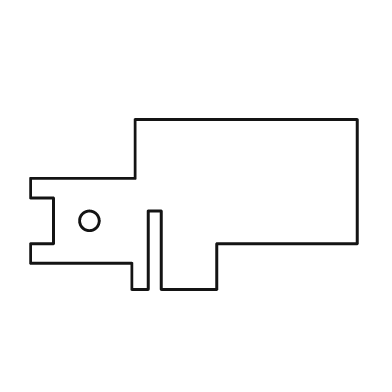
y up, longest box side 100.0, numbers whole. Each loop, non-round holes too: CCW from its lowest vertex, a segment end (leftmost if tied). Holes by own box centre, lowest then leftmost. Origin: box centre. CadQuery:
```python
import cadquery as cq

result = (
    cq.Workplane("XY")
    .moveTo(-19.0, -26.0)
    .lineTo(-14.0, -26.0)
    .lineTo(-14.0, -2.0)
    .lineTo(-10.0, -2.0)
    .lineTo(-10.0, -26.0)
    .lineTo(7.0, -26.0)
    .lineTo(7.0, -12.0)
    .lineTo(50.0, -12.0)
    .lineTo(50.0, 26.0)
    .lineTo(-18.0, 26.0)
    .lineTo(-18.0, 8.0)
    .lineTo(-50.0, 8.0)
    .lineTo(-50.0, 2.0)
    .lineTo(-43.0, 2.0)
    .lineTo(-43.0, -12.0)
    .lineTo(-50.0, -12.0)
    .lineTo(-50.0, -18.0)
    .lineTo(-19.0, -18.0)
    .close()
    .moveTo(-32.0, -5.0)
    .circle(3.0)
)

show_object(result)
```